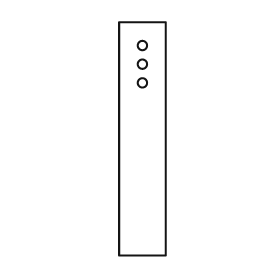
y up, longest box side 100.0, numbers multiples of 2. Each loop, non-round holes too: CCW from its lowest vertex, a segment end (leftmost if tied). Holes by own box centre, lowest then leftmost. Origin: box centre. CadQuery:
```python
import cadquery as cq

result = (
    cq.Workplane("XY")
    .moveTo(-10.0, -50.0)
    .lineTo(10.0, -50.0)
    .lineTo(10.0, 50.0)
    .lineTo(-10.0, 50.0)
    .close()
    .moveTo(0.0, 24.0)
    .circle(2.0)
    .moveTo(0.0, 32.0)
    .circle(2.0)
    .moveTo(0.0, 40.0)
    .circle(2.0)
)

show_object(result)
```